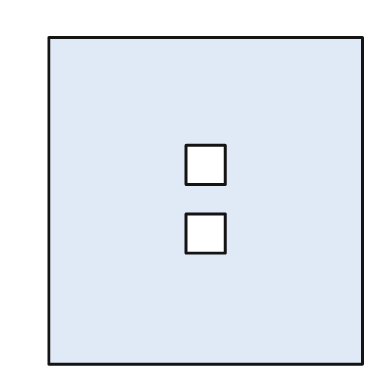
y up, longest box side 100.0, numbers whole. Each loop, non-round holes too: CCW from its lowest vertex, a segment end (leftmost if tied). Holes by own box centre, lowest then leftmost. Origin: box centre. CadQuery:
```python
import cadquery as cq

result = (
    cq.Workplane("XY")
    .moveTo(-48.0, -50.0)
    .lineTo(48.0, -50.0)
    .lineTo(48.0, 50.0)
    .lineTo(-48.0, 50.0)
    .close()
    .moveTo(-6.0, -16.0)
    .lineTo(6.0, -16.0)
    .lineTo(6.0, -4.0)
    .lineTo(-6.0, -4.0)
    .close()
    .moveTo(-6.0, 5.0)
    .lineTo(6.0, 5.0)
    .lineTo(6.0, 17.0)
    .lineTo(-6.0, 17.0)
    .close()
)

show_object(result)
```